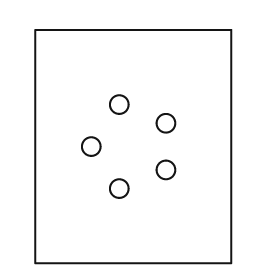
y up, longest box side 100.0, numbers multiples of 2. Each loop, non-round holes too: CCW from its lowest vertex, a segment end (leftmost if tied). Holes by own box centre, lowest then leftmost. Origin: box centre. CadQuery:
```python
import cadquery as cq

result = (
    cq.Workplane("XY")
    .moveTo(-42.0, -50.0)
    .lineTo(42.0, -50.0)
    .lineTo(42.0, 50.0)
    .lineTo(-42.0, 50.0)
    .close()
    .moveTo(-6.0, -18.0)
    .circle(4.0)
    .moveTo(14.0, -10.0)
    .circle(4.0)
    .moveTo(-18.0, 0.0)
    .circle(4.0)
    .moveTo(14.0, 10.0)
    .circle(4.0)
    .moveTo(-6.0, 18.0)
    .circle(4.0)
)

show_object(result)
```